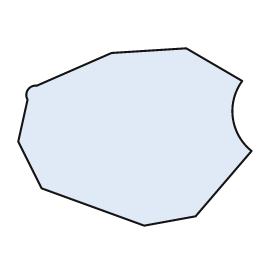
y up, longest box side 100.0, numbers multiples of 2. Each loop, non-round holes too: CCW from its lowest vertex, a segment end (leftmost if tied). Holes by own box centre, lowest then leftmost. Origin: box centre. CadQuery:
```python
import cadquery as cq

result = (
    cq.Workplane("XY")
    .moveTo(4.0, -38.0)
    .lineTo(26.0, -34.0)
    .lineTo(50.0, -6.0)
    .threePointArc((42.0, 8.0), (46.0, 24.0))
    .lineTo(22.0, 38.0)
    .lineTo(-10.0, 36.0)
    .lineTo(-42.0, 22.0)
    .threePointArc((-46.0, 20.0), (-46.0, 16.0))
    .lineTo(-50.0, -2.0)
    .lineTo(-40.0, -22.0)
    .close()
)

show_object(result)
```